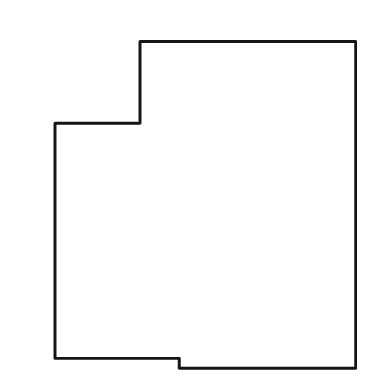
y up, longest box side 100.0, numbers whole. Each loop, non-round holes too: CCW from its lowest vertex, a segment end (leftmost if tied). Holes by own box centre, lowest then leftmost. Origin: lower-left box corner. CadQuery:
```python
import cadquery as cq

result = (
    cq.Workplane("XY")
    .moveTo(38.0, 0.0)
    .lineTo(92.0, 0.0)
    .lineTo(92.0, 100.0)
    .lineTo(26.0, 100.0)
    .lineTo(26.0, 75.0)
    .lineTo(0.0, 75.0)
    .lineTo(0.0, 3.0)
    .lineTo(38.0, 3.0)
    .close()
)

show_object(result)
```